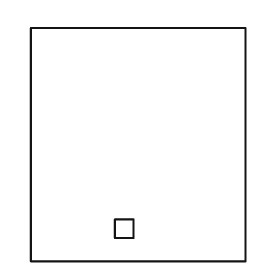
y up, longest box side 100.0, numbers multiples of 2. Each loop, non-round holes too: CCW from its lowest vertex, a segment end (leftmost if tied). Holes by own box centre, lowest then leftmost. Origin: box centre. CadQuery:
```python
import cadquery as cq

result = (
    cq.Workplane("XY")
    .moveTo(-46.0, -50.0)
    .lineTo(46.0, -50.0)
    .lineTo(46.0, 50.0)
    .lineTo(-46.0, 50.0)
    .close()
    .moveTo(-10.0, -40.0)
    .lineTo(-2.0, -40.0)
    .lineTo(-2.0, -32.0)
    .lineTo(-10.0, -32.0)
    .close()
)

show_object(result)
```